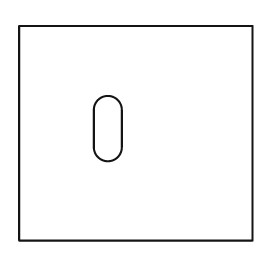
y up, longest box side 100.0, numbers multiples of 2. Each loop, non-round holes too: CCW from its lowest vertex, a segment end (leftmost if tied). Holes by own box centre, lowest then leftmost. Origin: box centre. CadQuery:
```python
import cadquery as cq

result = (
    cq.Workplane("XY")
    .moveTo(-50.0, -46.0)
    .lineTo(50.0, -46.0)
    .lineTo(50.0, 46.0)
    .lineTo(-50.0, 46.0)
    .close()
    .moveTo(-18.0, -6.0)
    .threePointArc((-12.0, -12.0), (-6.0, -6.0))
    .lineTo(-6.0, 10.0)
    .threePointArc((-12.0, 16.0), (-18.0, 10.0))
    .close()
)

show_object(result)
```